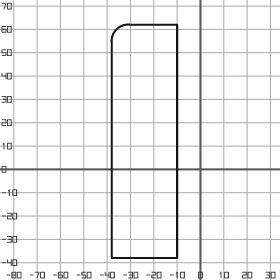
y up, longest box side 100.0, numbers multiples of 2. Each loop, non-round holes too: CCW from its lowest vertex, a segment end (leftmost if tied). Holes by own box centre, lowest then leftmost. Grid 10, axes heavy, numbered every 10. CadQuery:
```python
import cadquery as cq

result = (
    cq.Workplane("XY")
    .moveTo(-38.0, -38.0)
    .lineTo(-10.0, -38.0)
    .lineTo(-10.0, 62.0)
    .lineTo(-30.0, 62.0)
    .threePointArc((-36.0, 60.0), (-38.0, 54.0))
    .close()
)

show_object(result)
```